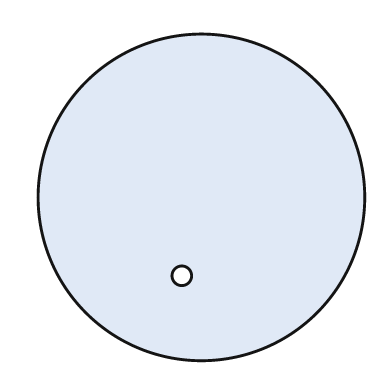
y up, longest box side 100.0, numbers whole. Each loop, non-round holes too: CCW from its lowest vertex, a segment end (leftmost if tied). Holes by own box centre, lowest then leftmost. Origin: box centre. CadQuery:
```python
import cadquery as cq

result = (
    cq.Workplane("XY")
    .moveTo(0.0, 0.0)
    .circle(50.0)
    .moveTo(-6.0, -24.0)
    .circle(3.0)
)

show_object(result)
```